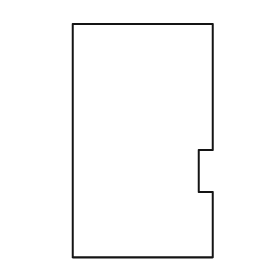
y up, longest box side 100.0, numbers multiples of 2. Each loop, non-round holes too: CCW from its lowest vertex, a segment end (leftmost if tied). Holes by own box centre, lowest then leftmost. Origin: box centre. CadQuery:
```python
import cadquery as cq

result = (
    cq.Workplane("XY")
    .moveTo(-30.0, -50.0)
    .lineTo(30.0, -50.0)
    .lineTo(30.0, -22.0)
    .lineTo(24.0, -22.0)
    .lineTo(24.0, -4.0)
    .lineTo(30.0, -4.0)
    .lineTo(30.0, 50.0)
    .lineTo(-30.0, 50.0)
    .close()
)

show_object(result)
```